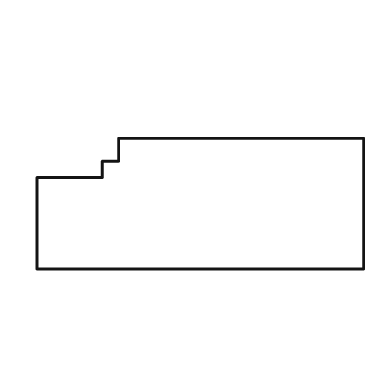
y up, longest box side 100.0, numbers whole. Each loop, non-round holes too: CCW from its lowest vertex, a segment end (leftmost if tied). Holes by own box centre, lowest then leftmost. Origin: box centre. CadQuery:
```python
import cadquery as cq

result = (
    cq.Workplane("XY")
    .moveTo(-50.0, -20.0)
    .lineTo(50.0, -20.0)
    .lineTo(50.0, 20.0)
    .lineTo(-25.0, 20.0)
    .lineTo(-25.0, 13.0)
    .lineTo(-30.0, 13.0)
    .lineTo(-30.0, 8.0)
    .lineTo(-50.0, 8.0)
    .close()
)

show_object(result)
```